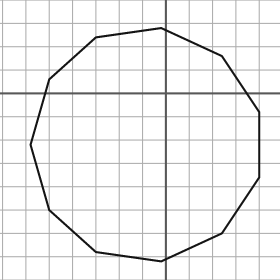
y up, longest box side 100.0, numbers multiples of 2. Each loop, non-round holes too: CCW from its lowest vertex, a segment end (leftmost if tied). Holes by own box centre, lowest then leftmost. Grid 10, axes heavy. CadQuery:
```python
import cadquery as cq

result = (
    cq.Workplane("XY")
    .moveTo(-2.0, -72.0)
    .lineTo(24.0, -60.0)
    .lineTo(40.0, -36.0)
    .lineTo(40.0, -8.0)
    .lineTo(24.0, 16.0)
    .lineTo(-2.0, 28.0)
    .lineTo(-30.0, 24.0)
    .lineTo(-50.0, 6.0)
    .lineTo(-58.0, -22.0)
    .lineTo(-50.0, -50.0)
    .lineTo(-30.0, -68.0)
    .close()
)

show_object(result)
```